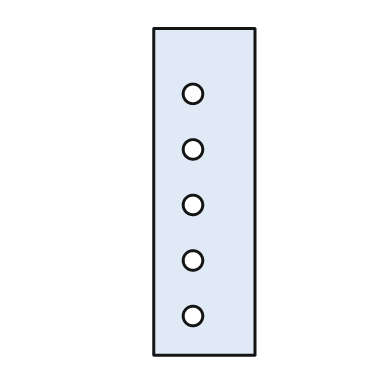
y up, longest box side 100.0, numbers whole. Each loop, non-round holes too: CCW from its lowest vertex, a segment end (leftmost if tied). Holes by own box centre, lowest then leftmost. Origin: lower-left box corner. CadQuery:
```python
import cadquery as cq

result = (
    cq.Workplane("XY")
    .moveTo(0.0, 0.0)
    .lineTo(31.0, 0.0)
    .lineTo(31.0, 100.0)
    .lineTo(0.0, 100.0)
    .close()
    .moveTo(12.0, 12.0)
    .circle(3.0)
    .moveTo(12.0, 29.0)
    .circle(3.0)
    .moveTo(12.0, 46.0)
    .circle(3.0)
    .moveTo(12.0, 63.0)
    .circle(3.0)
    .moveTo(12.0, 80.0)
    .circle(3.0)
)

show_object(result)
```